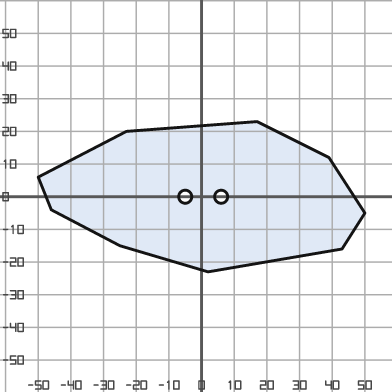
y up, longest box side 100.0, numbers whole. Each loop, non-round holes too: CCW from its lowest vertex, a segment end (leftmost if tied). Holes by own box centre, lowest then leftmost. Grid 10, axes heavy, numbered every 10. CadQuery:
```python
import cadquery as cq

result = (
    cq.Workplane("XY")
    .moveTo(2.0, -23.0)
    .lineTo(43.0, -16.0)
    .lineTo(50.0, -5.0)
    .lineTo(39.0, 12.0)
    .lineTo(17.0, 23.0)
    .lineTo(-23.0, 20.0)
    .lineTo(-50.0, 6.0)
    .lineTo(-46.0, -4.0)
    .lineTo(-25.0, -15.0)
    .close()
    .moveTo(-5.0, 0.0)
    .circle(2.0)
    .moveTo(6.0, 0.0)
    .circle(2.0)
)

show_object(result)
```